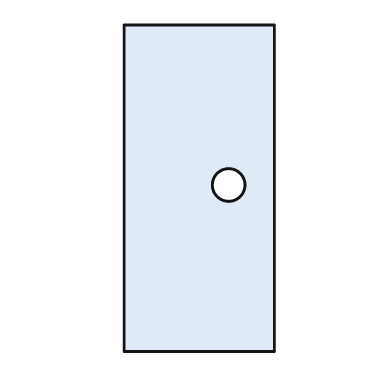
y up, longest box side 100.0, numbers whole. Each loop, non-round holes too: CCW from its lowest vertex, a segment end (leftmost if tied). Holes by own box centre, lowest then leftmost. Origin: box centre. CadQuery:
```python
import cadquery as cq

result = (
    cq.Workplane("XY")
    .moveTo(-23.0, -50.0)
    .lineTo(23.0, -50.0)
    .lineTo(23.0, 50.0)
    .lineTo(-23.0, 50.0)
    .close()
    .moveTo(9.0, 1.0)
    .circle(5.0)
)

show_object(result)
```